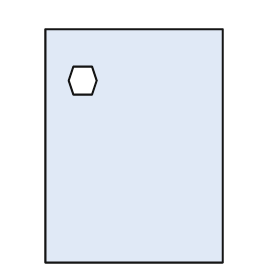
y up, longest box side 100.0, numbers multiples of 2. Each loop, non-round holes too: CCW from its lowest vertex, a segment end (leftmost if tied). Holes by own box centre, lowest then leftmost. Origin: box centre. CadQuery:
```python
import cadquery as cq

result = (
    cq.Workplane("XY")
    .moveTo(-38.0, -50.0)
    .lineTo(38.0, -50.0)
    .lineTo(38.0, 50.0)
    .lineTo(-38.0, 50.0)
    .close()
    .moveTo(-26.0, 22.0)
    .lineTo(-18.0, 22.0)
    .lineTo(-16.0, 28.0)
    .lineTo(-18.0, 34.0)
    .lineTo(-26.0, 34.0)
    .lineTo(-28.0, 28.0)
    .close()
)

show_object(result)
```